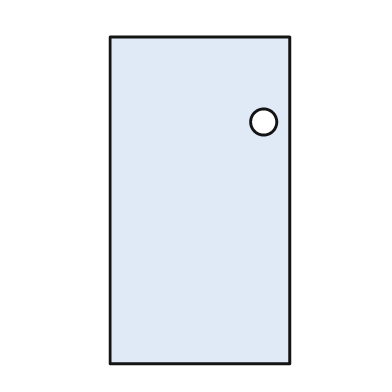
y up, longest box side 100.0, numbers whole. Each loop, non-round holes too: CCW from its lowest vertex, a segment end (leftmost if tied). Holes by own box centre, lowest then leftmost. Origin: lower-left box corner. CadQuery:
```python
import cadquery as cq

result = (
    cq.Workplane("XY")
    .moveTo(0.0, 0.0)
    .lineTo(55.0, 0.0)
    .lineTo(55.0, 100.0)
    .lineTo(0.0, 100.0)
    .close()
    .moveTo(47.0, 74.0)
    .circle(4.0)
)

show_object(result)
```